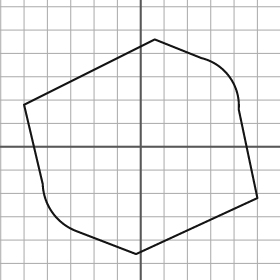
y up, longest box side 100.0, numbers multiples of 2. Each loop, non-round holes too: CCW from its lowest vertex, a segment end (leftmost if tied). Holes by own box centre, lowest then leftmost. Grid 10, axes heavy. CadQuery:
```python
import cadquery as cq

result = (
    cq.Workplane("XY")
    .moveTo(-2.0, -46.0)
    .lineTo(50.0, -22.0)
    .lineTo(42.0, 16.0)
    .threePointArc((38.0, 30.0), (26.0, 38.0))
    .lineTo(6.0, 46.0)
    .lineTo(-50.0, 18.0)
    .lineTo(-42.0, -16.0)
    .threePointArc((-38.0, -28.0), (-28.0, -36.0))
    .close()
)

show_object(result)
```